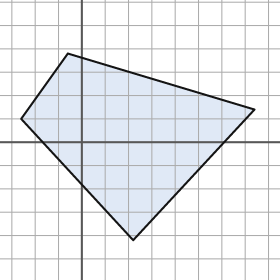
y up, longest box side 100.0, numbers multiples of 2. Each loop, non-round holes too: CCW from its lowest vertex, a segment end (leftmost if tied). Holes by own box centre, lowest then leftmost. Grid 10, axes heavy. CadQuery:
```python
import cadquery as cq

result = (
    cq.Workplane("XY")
    .moveTo(22.0, -42.0)
    .lineTo(74.0, 14.0)
    .lineTo(-6.0, 38.0)
    .lineTo(-26.0, 10.0)
    .close()
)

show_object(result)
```